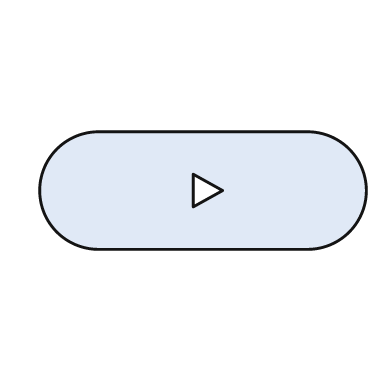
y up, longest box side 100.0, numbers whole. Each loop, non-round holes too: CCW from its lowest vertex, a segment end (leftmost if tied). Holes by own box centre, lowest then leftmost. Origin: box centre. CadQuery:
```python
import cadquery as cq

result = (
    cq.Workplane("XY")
    .moveTo(-32.0, -18.0)
    .lineTo(32.0, -18.0)
    .threePointArc((50.0, 0.0), (32.0, 18.0))
    .lineTo(-32.0, 18.0)
    .threePointArc((-50.0, 0.0), (-32.0, -18.0))
    .close()
    .moveTo(-3.0, -5.0)
    .lineTo(6.0, 0.0)
    .lineTo(-3.0, 5.0)
    .close()
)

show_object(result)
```